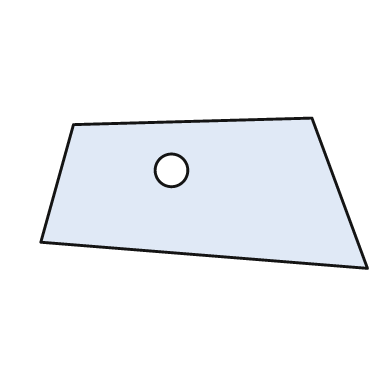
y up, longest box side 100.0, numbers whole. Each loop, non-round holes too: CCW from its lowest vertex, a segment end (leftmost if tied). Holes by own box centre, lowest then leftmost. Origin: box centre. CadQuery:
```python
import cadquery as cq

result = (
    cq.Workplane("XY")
    .moveTo(50.0, -23.0)
    .lineTo(33.0, 23.0)
    .lineTo(-40.0, 21.0)
    .lineTo(-50.0, -15.0)
    .close()
    .moveTo(-10.0, 7.0)
    .circle(5.0)
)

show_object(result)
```